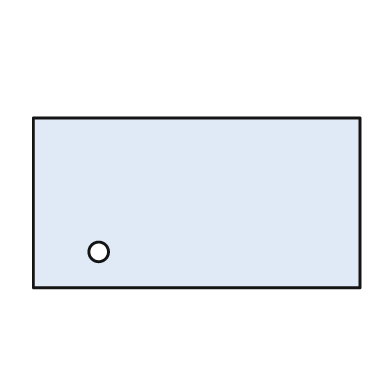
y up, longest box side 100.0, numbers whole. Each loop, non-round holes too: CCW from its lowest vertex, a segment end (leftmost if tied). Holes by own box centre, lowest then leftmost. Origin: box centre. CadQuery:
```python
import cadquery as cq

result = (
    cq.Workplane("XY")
    .moveTo(-50.0, -26.0)
    .lineTo(50.0, -26.0)
    .lineTo(50.0, 26.0)
    .lineTo(-50.0, 26.0)
    .close()
    .moveTo(-30.0, -15.0)
    .circle(3.0)
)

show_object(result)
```